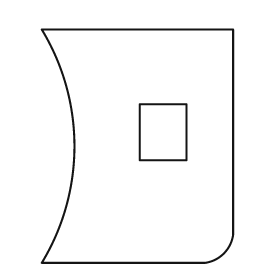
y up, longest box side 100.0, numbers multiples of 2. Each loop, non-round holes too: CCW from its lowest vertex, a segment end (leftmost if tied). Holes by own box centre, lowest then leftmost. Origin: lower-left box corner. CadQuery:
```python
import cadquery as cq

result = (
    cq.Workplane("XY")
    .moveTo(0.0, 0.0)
    .lineTo(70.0, 0.0)
    .threePointArc((78.0, 4.0), (82.0, 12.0))
    .lineTo(82.0, 100.0)
    .lineTo(0.0, 100.0)
    .threePointArc((14.0, 50.0), (0.0, 0.0))
    .close()
    .moveTo(42.0, 44.0)
    .lineTo(62.0, 44.0)
    .lineTo(62.0, 68.0)
    .lineTo(42.0, 68.0)
    .close()
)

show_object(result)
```